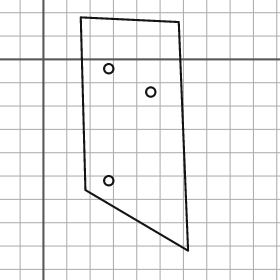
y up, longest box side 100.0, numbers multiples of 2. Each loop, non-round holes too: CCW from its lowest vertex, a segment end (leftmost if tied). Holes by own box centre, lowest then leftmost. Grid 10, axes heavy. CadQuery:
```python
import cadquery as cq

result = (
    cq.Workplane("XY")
    .moveTo(62.0, -82.0)
    .lineTo(58.0, 16.0)
    .lineTo(16.0, 18.0)
    .lineTo(18.0, -56.0)
    .close()
    .moveTo(28.0, -52.0)
    .circle(2.0)
    .moveTo(46.0, -14.0)
    .circle(2.0)
    .moveTo(28.0, -4.0)
    .circle(2.0)
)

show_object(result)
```